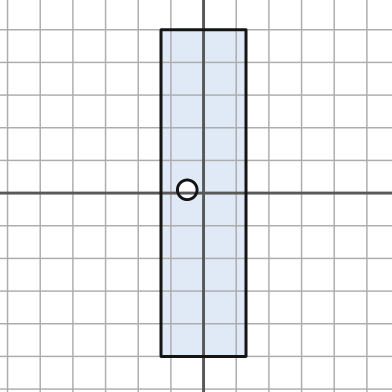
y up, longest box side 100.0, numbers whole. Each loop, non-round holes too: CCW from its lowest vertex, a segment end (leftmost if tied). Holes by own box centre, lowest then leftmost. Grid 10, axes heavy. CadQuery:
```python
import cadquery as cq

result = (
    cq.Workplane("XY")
    .moveTo(-13.0, -50.0)
    .lineTo(13.0, -50.0)
    .lineTo(13.0, 50.0)
    .lineTo(-13.0, 50.0)
    .close()
    .moveTo(-5.0, 1.0)
    .circle(3.0)
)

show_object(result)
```